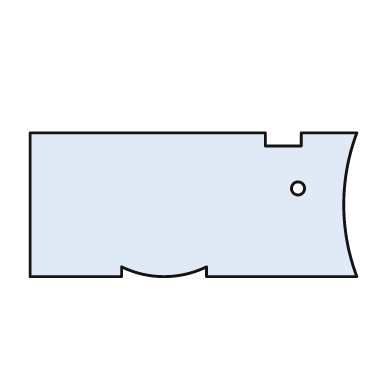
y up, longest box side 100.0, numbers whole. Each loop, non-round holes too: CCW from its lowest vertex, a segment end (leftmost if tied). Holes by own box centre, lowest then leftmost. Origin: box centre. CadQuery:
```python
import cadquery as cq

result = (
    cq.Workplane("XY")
    .moveTo(-50.0, -22.0)
    .lineTo(-22.0, -22.0)
    .lineTo(-22.0, -19.0)
    .threePointArc((-9.0, -22.0), (4.0, -19.0))
    .lineTo(4.0, -22.0)
    .lineTo(50.0, -22.0)
    .threePointArc((46.0, 0.0), (50.0, 22.0))
    .lineTo(33.0, 22.0)
    .lineTo(33.0, 18.0)
    .lineTo(22.0, 18.0)
    .lineTo(22.0, 22.0)
    .lineTo(-50.0, 22.0)
    .close()
    .moveTo(32.0, 5.0)
    .circle(2.0)
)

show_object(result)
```